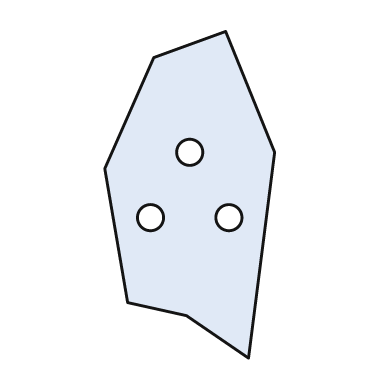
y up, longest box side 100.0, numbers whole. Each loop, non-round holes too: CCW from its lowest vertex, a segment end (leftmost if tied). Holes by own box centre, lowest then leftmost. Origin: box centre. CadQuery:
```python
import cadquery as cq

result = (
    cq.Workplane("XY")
    .moveTo(18.0, -50.0)
    .lineTo(26.0, 13.0)
    .lineTo(11.0, 50.0)
    .lineTo(-11.0, 42.0)
    .lineTo(-26.0, 8.0)
    .lineTo(-19.0, -33.0)
    .lineTo(-1.0, -37.0)
    .close()
    .moveTo(-12.0, -7.0)
    .circle(4.0)
    .moveTo(12.0, -7.0)
    .circle(4.0)
    .moveTo(0.0, 13.0)
    .circle(4.0)
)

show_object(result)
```